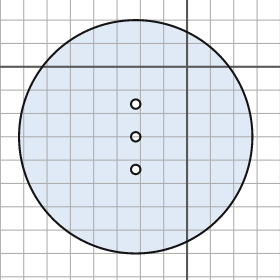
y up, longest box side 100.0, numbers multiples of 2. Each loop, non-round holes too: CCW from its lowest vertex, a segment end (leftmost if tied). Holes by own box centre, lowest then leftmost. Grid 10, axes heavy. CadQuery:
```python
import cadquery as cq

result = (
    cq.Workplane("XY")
    .moveTo(-22.0, -30.0)
    .circle(50.0)
    .moveTo(-22.0, -44.0)
    .circle(2.0)
    .moveTo(-22.0, -30.0)
    .circle(2.0)
    .moveTo(-22.0, -16.0)
    .circle(2.0)
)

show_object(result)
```